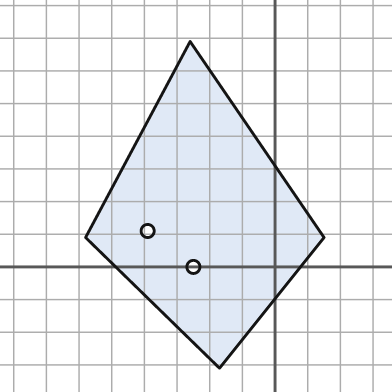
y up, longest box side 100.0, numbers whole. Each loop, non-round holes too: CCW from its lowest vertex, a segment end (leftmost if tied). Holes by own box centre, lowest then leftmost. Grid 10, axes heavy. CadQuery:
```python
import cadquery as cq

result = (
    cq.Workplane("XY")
    .moveTo(-17.0, -31.0)
    .lineTo(15.0, 9.0)
    .lineTo(-26.0, 69.0)
    .lineTo(-58.0, 9.0)
    .close()
    .moveTo(-25.0, 0.0)
    .circle(2.0)
    .moveTo(-39.0, 11.0)
    .circle(2.0)
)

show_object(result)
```